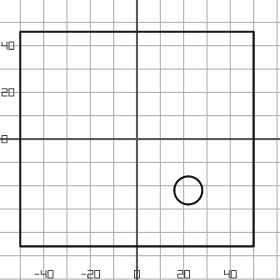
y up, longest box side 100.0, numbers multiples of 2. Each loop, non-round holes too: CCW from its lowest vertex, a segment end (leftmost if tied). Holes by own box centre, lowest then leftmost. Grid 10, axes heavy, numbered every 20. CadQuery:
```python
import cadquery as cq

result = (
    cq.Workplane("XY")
    .moveTo(-50.0, -46.0)
    .lineTo(50.0, -46.0)
    .lineTo(50.0, 46.0)
    .lineTo(-50.0, 46.0)
    .close()
    .moveTo(22.0, -22.0)
    .circle(6.0)
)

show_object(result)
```